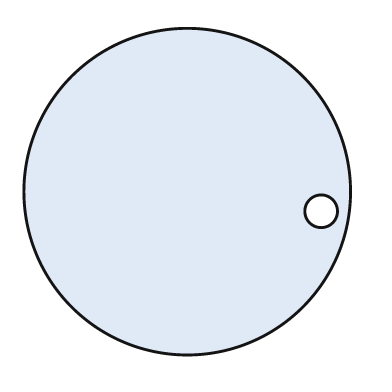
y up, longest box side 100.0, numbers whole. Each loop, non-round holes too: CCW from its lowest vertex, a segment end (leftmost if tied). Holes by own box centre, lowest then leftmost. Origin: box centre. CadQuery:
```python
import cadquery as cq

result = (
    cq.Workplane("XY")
    .moveTo(0.0, 0.0)
    .circle(50.0)
    .moveTo(41.0, -6.0)
    .circle(5.0)
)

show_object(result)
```